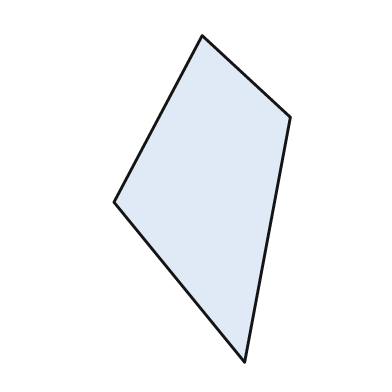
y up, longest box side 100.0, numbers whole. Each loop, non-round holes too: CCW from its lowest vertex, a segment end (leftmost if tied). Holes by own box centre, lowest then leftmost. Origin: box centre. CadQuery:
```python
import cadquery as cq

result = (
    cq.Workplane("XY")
    .moveTo(13.0, -50.0)
    .lineTo(27.0, 25.0)
    .lineTo(0.0, 50.0)
    .lineTo(-27.0, -1.0)
    .close()
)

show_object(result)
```